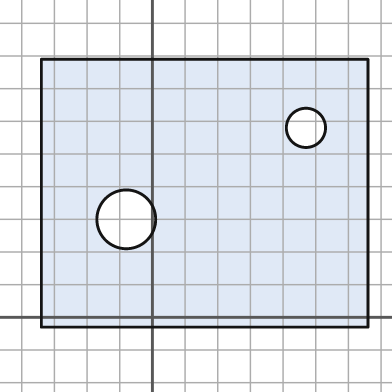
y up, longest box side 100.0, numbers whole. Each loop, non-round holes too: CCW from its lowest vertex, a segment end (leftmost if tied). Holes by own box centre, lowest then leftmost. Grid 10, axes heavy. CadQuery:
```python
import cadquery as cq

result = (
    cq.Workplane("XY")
    .moveTo(-34.0, -3.0)
    .lineTo(66.0, -3.0)
    .lineTo(66.0, 79.0)
    .lineTo(-34.0, 79.0)
    .close()
    .moveTo(-8.0, 30.0)
    .circle(9.0)
    .moveTo(47.0, 58.0)
    .circle(6.0)
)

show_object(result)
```